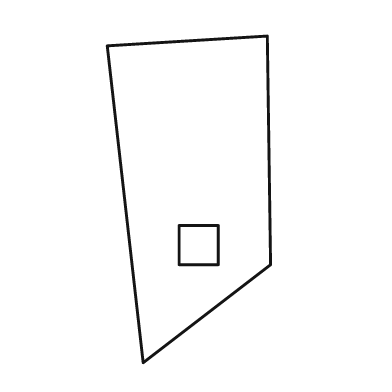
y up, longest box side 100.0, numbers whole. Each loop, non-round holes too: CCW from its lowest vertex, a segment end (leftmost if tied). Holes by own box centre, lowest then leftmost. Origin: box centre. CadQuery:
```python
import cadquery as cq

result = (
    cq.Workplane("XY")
    .moveTo(-14.0, -50.0)
    .lineTo(25.0, -20.0)
    .lineTo(24.0, 50.0)
    .lineTo(-25.0, 47.0)
    .close()
    .moveTo(-3.0, -20.0)
    .lineTo(9.0, -20.0)
    .lineTo(9.0, -8.0)
    .lineTo(-3.0, -8.0)
    .close()
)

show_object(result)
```